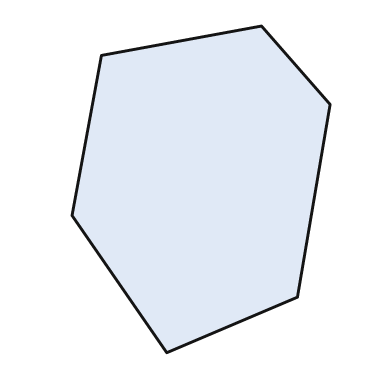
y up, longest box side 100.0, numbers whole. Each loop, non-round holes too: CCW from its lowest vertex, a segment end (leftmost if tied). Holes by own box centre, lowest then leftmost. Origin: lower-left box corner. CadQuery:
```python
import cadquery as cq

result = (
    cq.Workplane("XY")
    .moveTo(29.0, 0.0)
    .lineTo(69.0, 17.0)
    .lineTo(79.0, 76.0)
    .lineTo(58.0, 100.0)
    .lineTo(9.0, 91.0)
    .lineTo(0.0, 42.0)
    .close()
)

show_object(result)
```